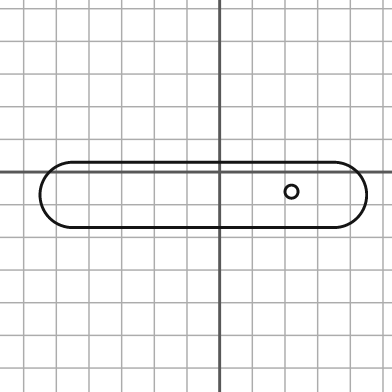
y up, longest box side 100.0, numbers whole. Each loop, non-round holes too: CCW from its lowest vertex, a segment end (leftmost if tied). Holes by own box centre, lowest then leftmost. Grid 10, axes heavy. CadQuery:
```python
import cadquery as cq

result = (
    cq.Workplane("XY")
    .moveTo(-45.0, -17.0)
    .lineTo(35.0, -17.0)
    .threePointArc((45.0, -7.0), (35.0, 3.0))
    .lineTo(-45.0, 3.0)
    .threePointArc((-55.0, -7.0), (-45.0, -17.0))
    .close()
    .moveTo(22.0, -6.0)
    .circle(2.0)
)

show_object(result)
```